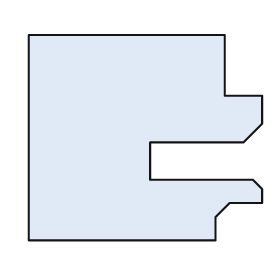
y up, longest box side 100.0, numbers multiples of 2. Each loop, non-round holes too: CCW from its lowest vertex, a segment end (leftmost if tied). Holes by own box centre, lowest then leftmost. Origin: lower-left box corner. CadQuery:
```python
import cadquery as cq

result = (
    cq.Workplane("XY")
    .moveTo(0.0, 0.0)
    .lineTo(80.0, 0.0)
    .lineTo(80.0, 10.0)
    .lineTo(86.0, 16.0)
    .lineTo(100.0, 16.0)
    .lineTo(100.0, 22.0)
    .lineTo(96.0, 26.0)
    .lineTo(52.0, 26.0)
    .lineTo(52.0, 42.0)
    .lineTo(92.0, 42.0)
    .lineTo(100.0, 50.0)
    .lineTo(100.0, 62.0)
    .lineTo(84.0, 62.0)
    .lineTo(84.0, 88.0)
    .lineTo(0.0, 88.0)
    .close()
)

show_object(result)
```